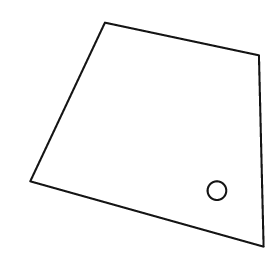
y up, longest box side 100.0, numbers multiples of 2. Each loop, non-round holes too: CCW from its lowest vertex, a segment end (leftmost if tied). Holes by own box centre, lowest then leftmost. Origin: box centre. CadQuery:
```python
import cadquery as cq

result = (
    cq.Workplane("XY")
    .moveTo(50.0, -48.0)
    .lineTo(48.0, 34.0)
    .lineTo(-18.0, 48.0)
    .lineTo(-50.0, -20.0)
    .close()
    .moveTo(30.0, -24.0)
    .circle(4.0)
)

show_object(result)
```